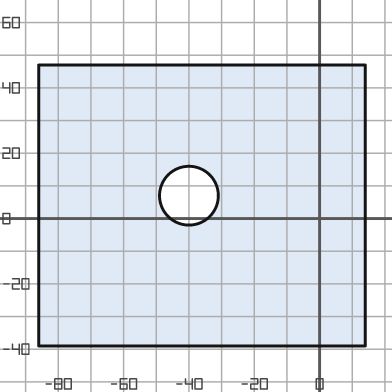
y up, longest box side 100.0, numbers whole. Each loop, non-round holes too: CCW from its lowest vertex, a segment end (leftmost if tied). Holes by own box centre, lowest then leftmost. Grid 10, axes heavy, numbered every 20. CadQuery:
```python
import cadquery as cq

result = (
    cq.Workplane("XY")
    .moveTo(-86.0, -39.0)
    .lineTo(14.0, -39.0)
    .lineTo(14.0, 47.0)
    .lineTo(-86.0, 47.0)
    .close()
    .moveTo(-40.0, 7.0)
    .circle(9.0)
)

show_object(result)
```